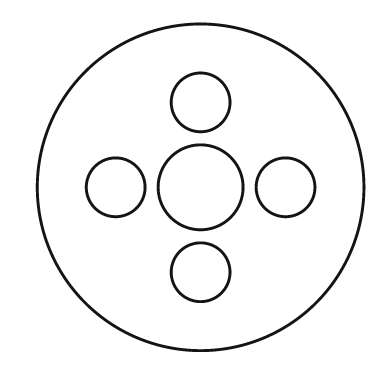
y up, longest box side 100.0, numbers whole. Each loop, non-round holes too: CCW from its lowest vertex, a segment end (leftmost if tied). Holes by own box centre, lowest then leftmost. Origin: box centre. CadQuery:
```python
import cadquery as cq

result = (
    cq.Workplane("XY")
    .moveTo(0.0, 0.0)
    .circle(50.0)
    .moveTo(0.0, -26.0)
    .circle(9.0)
    .moveTo(-26.0, 0.0)
    .circle(9.0)
    .moveTo(0.0, 0.0)
    .circle(13.0)
    .moveTo(26.0, 0.0)
    .circle(9.0)
    .moveTo(0.0, 26.0)
    .circle(9.0)
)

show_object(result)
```